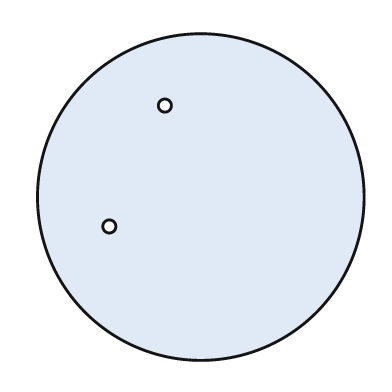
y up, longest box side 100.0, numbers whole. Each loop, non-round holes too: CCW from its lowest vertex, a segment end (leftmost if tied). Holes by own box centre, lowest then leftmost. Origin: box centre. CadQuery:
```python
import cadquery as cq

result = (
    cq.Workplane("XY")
    .moveTo(0.0, 0.0)
    .circle(50.0)
    .moveTo(-28.0, -9.0)
    .circle(2.0)
    .moveTo(-11.0, 28.0)
    .circle(2.0)
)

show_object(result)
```